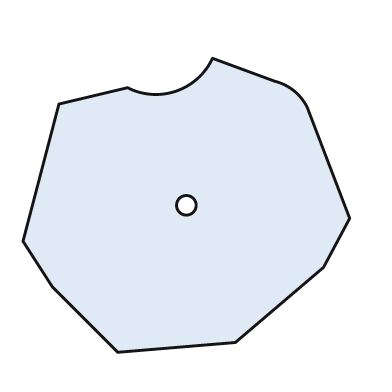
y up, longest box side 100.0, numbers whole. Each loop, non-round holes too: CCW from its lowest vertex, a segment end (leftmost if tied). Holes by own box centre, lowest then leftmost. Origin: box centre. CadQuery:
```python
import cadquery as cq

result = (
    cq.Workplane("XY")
    .moveTo(-21.0, -45.0)
    .lineTo(15.0, -42.0)
    .lineTo(42.0, -19.0)
    .lineTo(50.0, -4.0)
    .lineTo(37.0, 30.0)
    .threePointArc((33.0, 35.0), (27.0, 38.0))
    .lineTo(8.0, 45.0)
    .threePointArc((-3.0, 35.0), (-18.0, 36.0))
    .lineTo(-39.0, 31.0)
    .lineTo(-50.0, -11.0)
    .lineTo(-41.0, -25.0)
    .close()
    .moveTo(0.0, 0.0)
    .circle(3.0)
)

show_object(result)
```